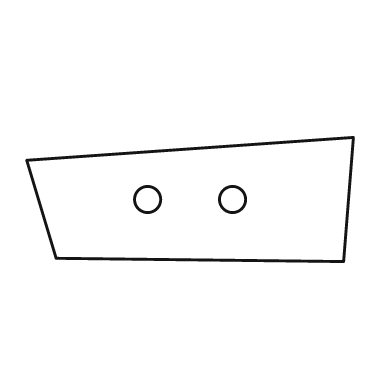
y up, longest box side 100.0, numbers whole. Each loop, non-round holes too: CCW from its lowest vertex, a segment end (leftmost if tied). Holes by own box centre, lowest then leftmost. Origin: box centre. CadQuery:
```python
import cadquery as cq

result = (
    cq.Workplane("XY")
    .moveTo(47.0, -19.0)
    .lineTo(50.0, 19.0)
    .lineTo(-50.0, 12.0)
    .lineTo(-41.0, -18.0)
    .close()
    .moveTo(-13.0, 0.0)
    .circle(4.0)
    .moveTo(13.0, 0.0)
    .circle(4.0)
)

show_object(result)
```